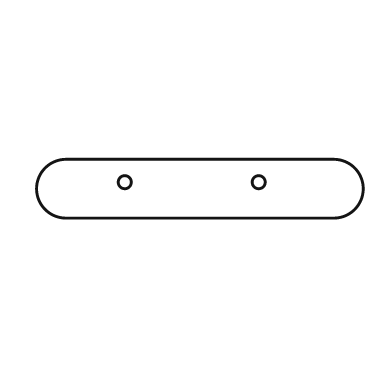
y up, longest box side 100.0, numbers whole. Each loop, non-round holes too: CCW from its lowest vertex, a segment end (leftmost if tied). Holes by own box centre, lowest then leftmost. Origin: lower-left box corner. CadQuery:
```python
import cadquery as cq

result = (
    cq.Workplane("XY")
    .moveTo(9.0, 0.0)
    .lineTo(91.0, 0.0)
    .threePointArc((100.0, 9.0), (91.0, 18.0))
    .lineTo(9.0, 18.0)
    .threePointArc((0.0, 9.0), (9.0, 0.0))
    .close()
    .moveTo(27.0, 11.0)
    .circle(2.0)
    .moveTo(68.0, 11.0)
    .circle(2.0)
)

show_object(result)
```